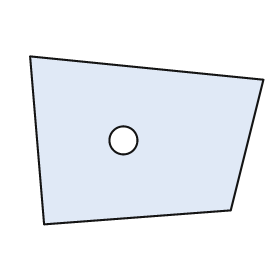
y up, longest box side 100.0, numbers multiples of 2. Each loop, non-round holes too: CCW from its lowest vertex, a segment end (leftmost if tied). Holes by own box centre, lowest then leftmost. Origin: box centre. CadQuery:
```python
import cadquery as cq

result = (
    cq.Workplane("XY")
    .moveTo(-44.0, -36.0)
    .lineTo(36.0, -30.0)
    .lineTo(50.0, 26.0)
    .lineTo(-50.0, 36.0)
    .close()
    .moveTo(-10.0, 0.0)
    .circle(6.0)
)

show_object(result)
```